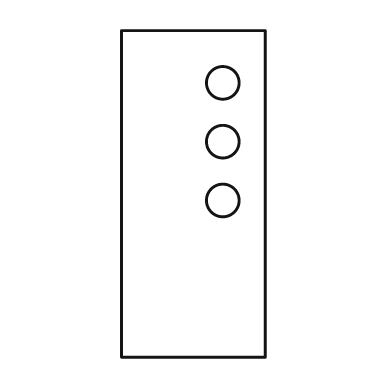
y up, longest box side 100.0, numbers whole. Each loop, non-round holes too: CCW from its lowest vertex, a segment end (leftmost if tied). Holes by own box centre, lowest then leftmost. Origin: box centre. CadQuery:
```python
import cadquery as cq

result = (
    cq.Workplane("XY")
    .moveTo(-22.0, -50.0)
    .lineTo(22.0, -50.0)
    .lineTo(22.0, 50.0)
    .lineTo(-22.0, 50.0)
    .close()
    .moveTo(9.0, -2.0)
    .circle(5.0)
    .moveTo(9.0, 16.0)
    .circle(5.0)
    .moveTo(9.0, 34.0)
    .circle(5.0)
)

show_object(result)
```